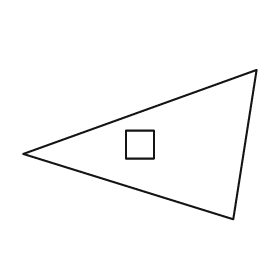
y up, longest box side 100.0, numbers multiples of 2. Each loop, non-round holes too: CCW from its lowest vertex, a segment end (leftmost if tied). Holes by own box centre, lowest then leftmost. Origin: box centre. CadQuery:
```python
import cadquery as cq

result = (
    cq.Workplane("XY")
    .moveTo(40.0, -32.0)
    .lineTo(50.0, 32.0)
    .lineTo(-50.0, -4.0)
    .close()
    .moveTo(-6.0, -6.0)
    .lineTo(6.0, -6.0)
    .lineTo(6.0, 6.0)
    .lineTo(-6.0, 6.0)
    .close()
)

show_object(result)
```